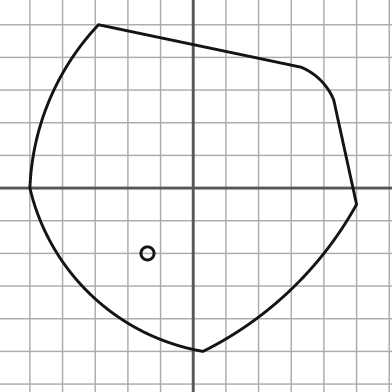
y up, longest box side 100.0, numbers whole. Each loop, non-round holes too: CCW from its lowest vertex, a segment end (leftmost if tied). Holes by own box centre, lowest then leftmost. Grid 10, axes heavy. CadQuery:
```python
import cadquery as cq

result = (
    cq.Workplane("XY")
    .moveTo(3.0, -50.0)
    .threePointArc((30.0, -31.0), (50.0, -5.0))
    .lineTo(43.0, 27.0)
    .threePointArc((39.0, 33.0), (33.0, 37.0))
    .lineTo(-29.0, 50.0)
    .threePointArc((-44.0, 27.0), (-50.0, 0.0))
    .threePointArc((-31.0, -33.0), (3.0, -50.0))
    .close()
    .moveTo(-14.0, -20.0)
    .circle(2.0)
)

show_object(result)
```